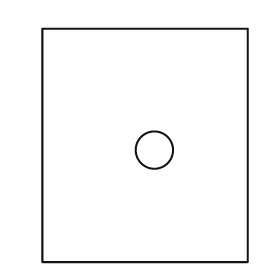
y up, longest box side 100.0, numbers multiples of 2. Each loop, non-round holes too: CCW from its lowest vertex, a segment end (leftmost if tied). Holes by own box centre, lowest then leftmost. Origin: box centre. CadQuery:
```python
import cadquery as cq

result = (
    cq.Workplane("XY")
    .moveTo(-44.0, -50.0)
    .lineTo(44.0, -50.0)
    .lineTo(44.0, 50.0)
    .lineTo(-44.0, 50.0)
    .close()
    .moveTo(4.0, -2.0)
    .circle(8.0)
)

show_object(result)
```